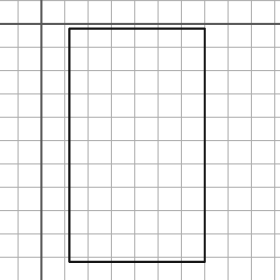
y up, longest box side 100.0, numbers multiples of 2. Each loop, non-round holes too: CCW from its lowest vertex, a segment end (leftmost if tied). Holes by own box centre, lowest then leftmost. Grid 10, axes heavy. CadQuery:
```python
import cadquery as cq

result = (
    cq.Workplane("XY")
    .moveTo(12.0, -102.0)
    .lineTo(70.0, -102.0)
    .lineTo(70.0, -2.0)
    .lineTo(12.0, -2.0)
    .close()
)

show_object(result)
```